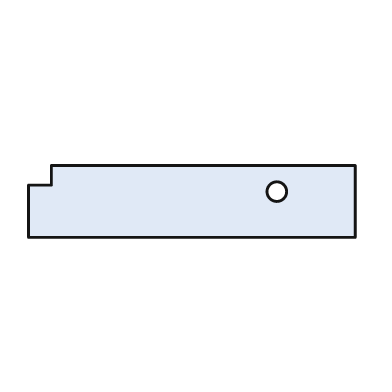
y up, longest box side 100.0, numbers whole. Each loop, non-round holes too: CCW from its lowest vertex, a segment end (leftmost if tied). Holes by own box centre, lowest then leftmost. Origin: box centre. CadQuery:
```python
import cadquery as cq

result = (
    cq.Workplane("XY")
    .moveTo(-50.0, -11.0)
    .lineTo(50.0, -11.0)
    .lineTo(50.0, 11.0)
    .lineTo(-43.0, 11.0)
    .lineTo(-43.0, 5.0)
    .lineTo(-50.0, 5.0)
    .close()
    .moveTo(26.0, 3.0)
    .circle(3.0)
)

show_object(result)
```